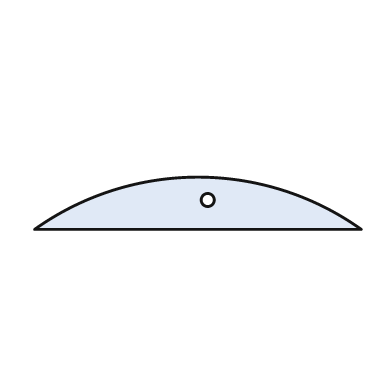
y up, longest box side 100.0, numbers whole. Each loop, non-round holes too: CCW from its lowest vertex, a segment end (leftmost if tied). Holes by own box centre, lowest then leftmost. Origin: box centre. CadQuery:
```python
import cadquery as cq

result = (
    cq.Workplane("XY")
    .moveTo(-50.0, -8.0)
    .lineTo(50.0, -8.0)
    .threePointArc((0.0, 8.0), (-50.0, -8.0))
    .close()
    .moveTo(3.0, 1.0)
    .circle(2.0)
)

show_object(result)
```